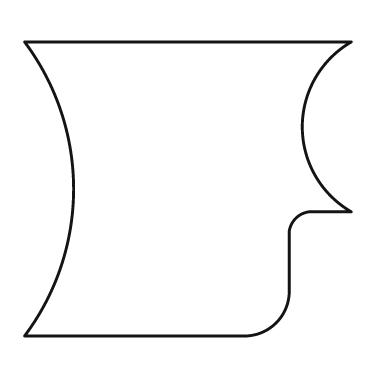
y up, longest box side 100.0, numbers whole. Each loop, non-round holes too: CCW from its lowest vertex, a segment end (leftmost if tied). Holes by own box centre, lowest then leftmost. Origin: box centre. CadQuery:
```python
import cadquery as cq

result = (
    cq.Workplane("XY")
    .moveTo(-50.0, -45.0)
    .lineTo(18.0, -45.0)
    .threePointArc((27.0, -41.0), (31.0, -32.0))
    .lineTo(31.0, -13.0)
    .threePointArc((33.0, -9.0), (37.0, -7.0))
    .lineTo(50.0, -7.0)
    .threePointArc((35.0, 19.0), (50.0, 45.0))
    .lineTo(-50.0, 45.0)
    .threePointArc((-35.0, 0.0), (-50.0, -45.0))
    .close()
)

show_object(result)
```